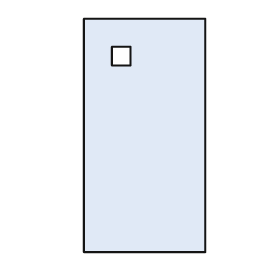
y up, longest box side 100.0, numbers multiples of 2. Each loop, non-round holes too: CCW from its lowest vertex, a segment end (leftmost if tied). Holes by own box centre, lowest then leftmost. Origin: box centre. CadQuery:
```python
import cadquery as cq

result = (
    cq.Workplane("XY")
    .moveTo(-26.0, -50.0)
    .lineTo(26.0, -50.0)
    .lineTo(26.0, 50.0)
    .lineTo(-26.0, 50.0)
    .close()
    .moveTo(-14.0, 30.0)
    .lineTo(-6.0, 30.0)
    .lineTo(-6.0, 38.0)
    .lineTo(-14.0, 38.0)
    .close()
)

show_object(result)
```